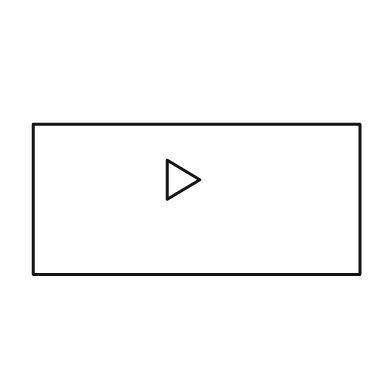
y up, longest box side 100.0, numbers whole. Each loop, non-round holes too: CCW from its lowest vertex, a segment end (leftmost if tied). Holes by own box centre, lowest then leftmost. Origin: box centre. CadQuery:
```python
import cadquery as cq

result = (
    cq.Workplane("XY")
    .moveTo(-50.0, -23.0)
    .lineTo(50.0, -23.0)
    .lineTo(50.0, 23.0)
    .lineTo(-50.0, 23.0)
    .close()
    .moveTo(-9.0, 0.0)
    .lineTo(1.0, 6.0)
    .lineTo(-9.0, 12.0)
    .close()
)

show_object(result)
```